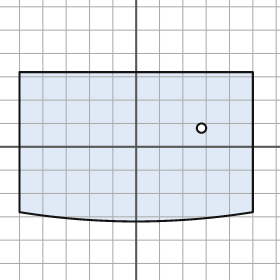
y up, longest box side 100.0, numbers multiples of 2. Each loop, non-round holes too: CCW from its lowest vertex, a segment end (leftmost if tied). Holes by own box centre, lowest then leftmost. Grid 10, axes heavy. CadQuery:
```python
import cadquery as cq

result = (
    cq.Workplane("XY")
    .moveTo(-50.0, -28.0)
    .threePointArc((0.0, -32.0), (50.0, -28.0))
    .lineTo(50.0, 32.0)
    .lineTo(-50.0, 32.0)
    .close()
    .moveTo(28.0, 8.0)
    .circle(2.0)
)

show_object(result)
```